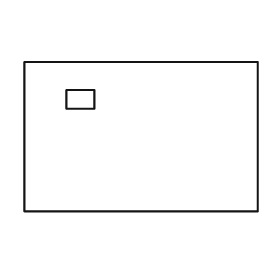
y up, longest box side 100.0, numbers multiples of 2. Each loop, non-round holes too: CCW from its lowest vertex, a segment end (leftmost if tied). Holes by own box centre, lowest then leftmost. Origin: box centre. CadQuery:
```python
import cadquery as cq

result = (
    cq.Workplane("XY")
    .moveTo(-50.0, -32.0)
    .lineTo(50.0, -32.0)
    .lineTo(50.0, 32.0)
    .lineTo(-50.0, 32.0)
    .close()
    .moveTo(-32.0, 12.0)
    .lineTo(-20.0, 12.0)
    .lineTo(-20.0, 20.0)
    .lineTo(-32.0, 20.0)
    .close()
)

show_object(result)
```